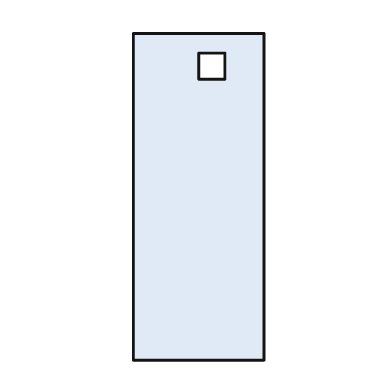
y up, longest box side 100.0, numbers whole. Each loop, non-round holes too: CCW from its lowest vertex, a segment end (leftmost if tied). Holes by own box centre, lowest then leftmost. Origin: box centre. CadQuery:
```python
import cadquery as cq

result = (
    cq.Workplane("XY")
    .moveTo(-20.0, -50.0)
    .lineTo(20.0, -50.0)
    .lineTo(20.0, 50.0)
    .lineTo(-20.0, 50.0)
    .close()
    .moveTo(0.0, 36.0)
    .lineTo(8.0, 36.0)
    .lineTo(8.0, 44.0)
    .lineTo(0.0, 44.0)
    .close()
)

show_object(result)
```